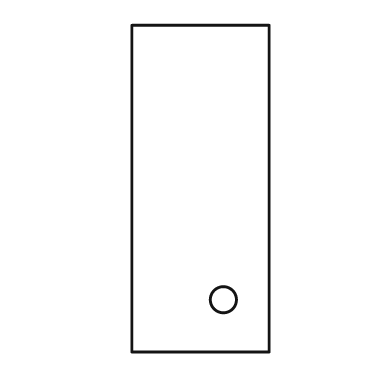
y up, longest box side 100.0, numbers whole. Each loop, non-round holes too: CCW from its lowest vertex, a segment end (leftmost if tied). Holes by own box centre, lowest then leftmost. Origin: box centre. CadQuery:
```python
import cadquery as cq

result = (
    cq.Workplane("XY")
    .moveTo(-21.0, -50.0)
    .lineTo(21.0, -50.0)
    .lineTo(21.0, 50.0)
    .lineTo(-21.0, 50.0)
    .close()
    .moveTo(7.0, -34.0)
    .circle(4.0)
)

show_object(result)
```